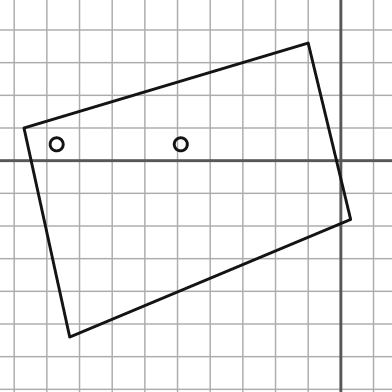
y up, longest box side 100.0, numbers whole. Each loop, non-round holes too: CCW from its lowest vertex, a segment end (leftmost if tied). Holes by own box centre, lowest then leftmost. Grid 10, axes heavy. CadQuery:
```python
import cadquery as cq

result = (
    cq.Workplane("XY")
    .moveTo(-83.0, -54.0)
    .lineTo(3.0, -18.0)
    .lineTo(-10.0, 36.0)
    .lineTo(-97.0, 10.0)
    .close()
    .moveTo(-87.0, 5.0)
    .circle(2.0)
    .moveTo(-49.0, 5.0)
    .circle(2.0)
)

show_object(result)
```